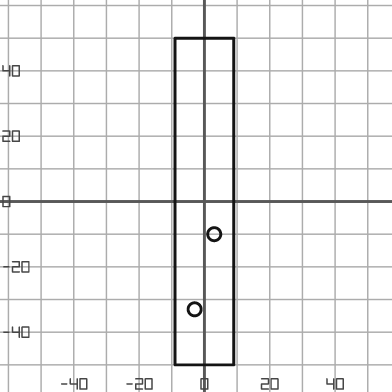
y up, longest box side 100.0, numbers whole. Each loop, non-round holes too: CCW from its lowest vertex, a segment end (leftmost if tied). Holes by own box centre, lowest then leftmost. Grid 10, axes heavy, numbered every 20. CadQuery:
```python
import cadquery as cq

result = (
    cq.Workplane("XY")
    .moveTo(-9.0, -50.0)
    .lineTo(9.0, -50.0)
    .lineTo(9.0, 50.0)
    .lineTo(-9.0, 50.0)
    .close()
    .moveTo(-3.0, -33.0)
    .circle(2.0)
    .moveTo(3.0, -10.0)
    .circle(2.0)
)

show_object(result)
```